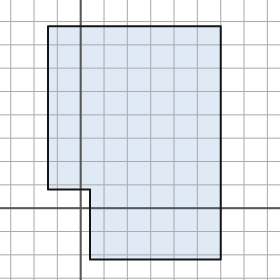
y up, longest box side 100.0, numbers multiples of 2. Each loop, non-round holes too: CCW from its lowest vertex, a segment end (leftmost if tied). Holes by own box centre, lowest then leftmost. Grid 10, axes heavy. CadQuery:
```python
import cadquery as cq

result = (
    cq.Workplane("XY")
    .moveTo(4.0, -22.0)
    .lineTo(60.0, -22.0)
    .lineTo(60.0, 78.0)
    .lineTo(-14.0, 78.0)
    .lineTo(-14.0, 8.0)
    .lineTo(4.0, 8.0)
    .close()
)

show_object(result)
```